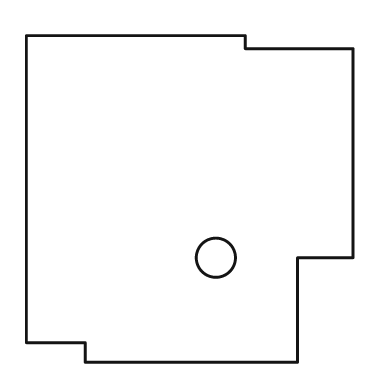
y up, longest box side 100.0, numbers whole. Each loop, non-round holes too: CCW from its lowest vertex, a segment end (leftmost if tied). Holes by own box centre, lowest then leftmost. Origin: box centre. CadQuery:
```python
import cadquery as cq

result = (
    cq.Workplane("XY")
    .moveTo(-32.0, -50.0)
    .lineTo(33.0, -50.0)
    .lineTo(33.0, -18.0)
    .lineTo(50.0, -18.0)
    .lineTo(50.0, 46.0)
    .lineTo(17.0, 46.0)
    .lineTo(17.0, 50.0)
    .lineTo(-50.0, 50.0)
    .lineTo(-50.0, -44.0)
    .lineTo(-32.0, -44.0)
    .close()
    .moveTo(8.0, -18.0)
    .circle(6.0)
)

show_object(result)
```